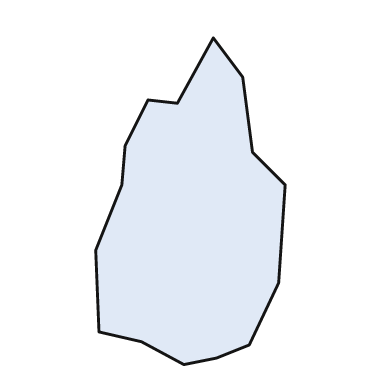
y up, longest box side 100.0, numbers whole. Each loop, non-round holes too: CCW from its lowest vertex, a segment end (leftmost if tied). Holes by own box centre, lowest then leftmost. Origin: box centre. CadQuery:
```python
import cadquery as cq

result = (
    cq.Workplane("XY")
    .moveTo(-2.0, -50.0)
    .lineTo(8.0, -48.0)
    .lineTo(18.0, -44.0)
    .lineTo(27.0, -25.0)
    .lineTo(29.0, 5.0)
    .lineTo(19.0, 15.0)
    .lineTo(16.0, 38.0)
    .lineTo(7.0, 50.0)
    .lineTo(-4.0, 30.0)
    .lineTo(-13.0, 31.0)
    .lineTo(-20.0, 17.0)
    .lineTo(-21.0, 5.0)
    .lineTo(-29.0, -15.0)
    .lineTo(-28.0, -40.0)
    .lineTo(-15.0, -43.0)
    .close()
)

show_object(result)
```